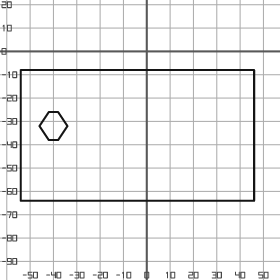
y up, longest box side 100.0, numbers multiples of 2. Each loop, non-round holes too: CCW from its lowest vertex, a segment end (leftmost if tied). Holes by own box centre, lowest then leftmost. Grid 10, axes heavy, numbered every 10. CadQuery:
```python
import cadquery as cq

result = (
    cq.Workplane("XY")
    .moveTo(-54.0, -64.0)
    .lineTo(46.0, -64.0)
    .lineTo(46.0, -8.0)
    .lineTo(-54.0, -8.0)
    .close()
    .moveTo(-42.0, -38.0)
    .lineTo(-38.0, -38.0)
    .lineTo(-34.0, -32.0)
    .lineTo(-38.0, -26.0)
    .lineTo(-42.0, -26.0)
    .lineTo(-46.0, -32.0)
    .close()
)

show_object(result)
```